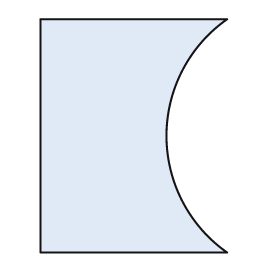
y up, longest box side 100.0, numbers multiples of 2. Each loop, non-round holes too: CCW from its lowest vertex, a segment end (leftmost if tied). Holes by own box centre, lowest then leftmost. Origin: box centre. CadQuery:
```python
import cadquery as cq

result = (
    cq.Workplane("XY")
    .moveTo(-40.0, -50.0)
    .lineTo(40.0, -50.0)
    .threePointArc((14.0, 0.0), (40.0, 50.0))
    .lineTo(-40.0, 50.0)
    .close()
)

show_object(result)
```